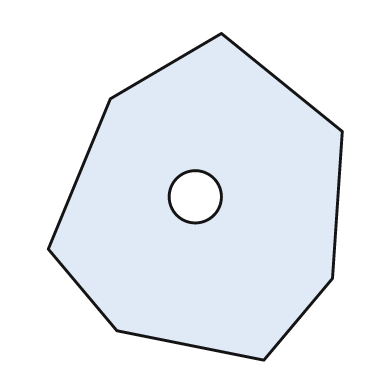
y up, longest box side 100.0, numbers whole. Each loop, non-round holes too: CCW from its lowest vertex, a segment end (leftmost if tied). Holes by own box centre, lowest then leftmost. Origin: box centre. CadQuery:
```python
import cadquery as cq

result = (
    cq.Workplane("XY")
    .moveTo(21.0, -50.0)
    .lineTo(42.0, -25.0)
    .lineTo(45.0, 20.0)
    .lineTo(8.0, 50.0)
    .lineTo(-26.0, 30.0)
    .lineTo(-45.0, -16.0)
    .lineTo(-24.0, -41.0)
    .close()
    .moveTo(0.0, 0.0)
    .circle(8.0)
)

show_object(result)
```